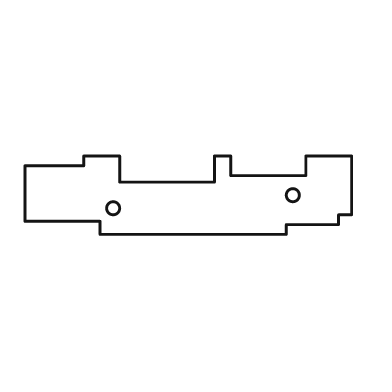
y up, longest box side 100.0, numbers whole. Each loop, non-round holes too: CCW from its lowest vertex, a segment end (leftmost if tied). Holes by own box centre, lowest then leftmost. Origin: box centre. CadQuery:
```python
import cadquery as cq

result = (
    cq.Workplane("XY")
    .moveTo(-27.0, -12.0)
    .lineTo(30.0, -12.0)
    .lineTo(30.0, -9.0)
    .lineTo(46.0, -9.0)
    .lineTo(46.0, -6.0)
    .lineTo(50.0, -6.0)
    .lineTo(50.0, 12.0)
    .lineTo(36.0, 12.0)
    .lineTo(36.0, 6.0)
    .lineTo(13.0, 6.0)
    .lineTo(13.0, 12.0)
    .lineTo(8.0, 12.0)
    .lineTo(8.0, 4.0)
    .lineTo(-21.0, 4.0)
    .lineTo(-21.0, 12.0)
    .lineTo(-32.0, 12.0)
    .lineTo(-32.0, 9.0)
    .lineTo(-50.0, 9.0)
    .lineTo(-50.0, -8.0)
    .lineTo(-27.0, -8.0)
    .close()
    .moveTo(-23.0, -4.0)
    .circle(2.0)
    .moveTo(32.0, 0.0)
    .circle(2.0)
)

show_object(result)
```